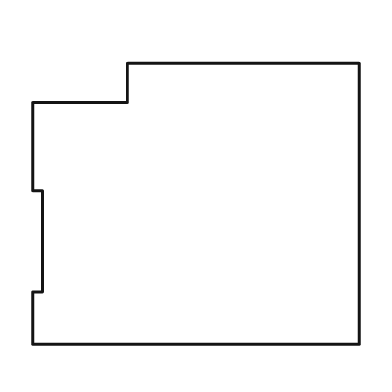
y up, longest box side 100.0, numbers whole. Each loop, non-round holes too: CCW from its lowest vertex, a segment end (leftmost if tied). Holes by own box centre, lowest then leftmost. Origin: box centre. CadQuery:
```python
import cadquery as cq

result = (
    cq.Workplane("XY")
    .moveTo(-50.0, -43.0)
    .lineTo(50.0, -43.0)
    .lineTo(50.0, 43.0)
    .lineTo(-21.0, 43.0)
    .lineTo(-21.0, 31.0)
    .lineTo(-50.0, 31.0)
    .lineTo(-50.0, 4.0)
    .lineTo(-47.0, 4.0)
    .lineTo(-47.0, -27.0)
    .lineTo(-50.0, -27.0)
    .close()
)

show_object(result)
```